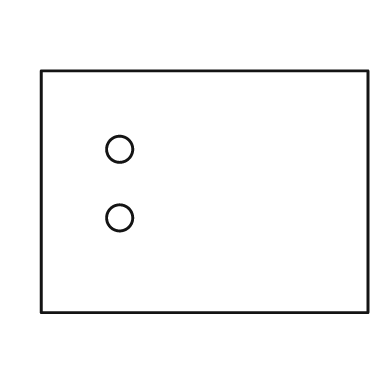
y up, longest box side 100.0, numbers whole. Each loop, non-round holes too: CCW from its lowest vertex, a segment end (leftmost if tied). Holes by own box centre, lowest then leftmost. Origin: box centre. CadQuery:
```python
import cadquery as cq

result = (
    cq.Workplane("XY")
    .moveTo(-50.0, -37.0)
    .lineTo(50.0, -37.0)
    .lineTo(50.0, 37.0)
    .lineTo(-50.0, 37.0)
    .close()
    .moveTo(-26.0, -8.0)
    .circle(4.0)
    .moveTo(-26.0, 13.0)
    .circle(4.0)
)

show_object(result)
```